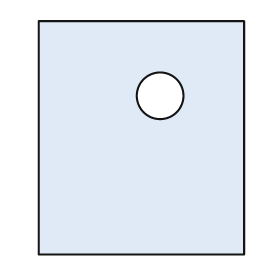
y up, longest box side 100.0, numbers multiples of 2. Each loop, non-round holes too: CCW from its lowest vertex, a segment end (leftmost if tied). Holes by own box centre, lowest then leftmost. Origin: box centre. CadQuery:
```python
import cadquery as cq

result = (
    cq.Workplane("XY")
    .moveTo(-44.0, -50.0)
    .lineTo(44.0, -50.0)
    .lineTo(44.0, 50.0)
    .lineTo(-44.0, 50.0)
    .close()
    .moveTo(8.0, 18.0)
    .circle(10.0)
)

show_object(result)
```